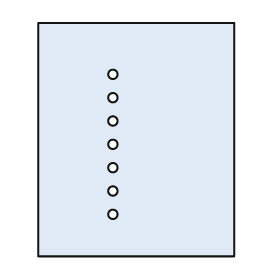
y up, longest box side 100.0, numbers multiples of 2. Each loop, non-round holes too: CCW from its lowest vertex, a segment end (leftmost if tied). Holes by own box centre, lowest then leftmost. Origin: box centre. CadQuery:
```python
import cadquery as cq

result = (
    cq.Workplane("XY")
    .moveTo(-42.0, -50.0)
    .lineTo(42.0, -50.0)
    .lineTo(42.0, 50.0)
    .lineTo(-42.0, 50.0)
    .close()
    .moveTo(-10.0, -32.0)
    .circle(2.0)
    .moveTo(-10.0, -22.0)
    .circle(2.0)
    .moveTo(-10.0, -12.0)
    .circle(2.0)
    .moveTo(-10.0, -2.0)
    .circle(2.0)
    .moveTo(-10.0, 8.0)
    .circle(2.0)
    .moveTo(-10.0, 18.0)
    .circle(2.0)
    .moveTo(-10.0, 28.0)
    .circle(2.0)
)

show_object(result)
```